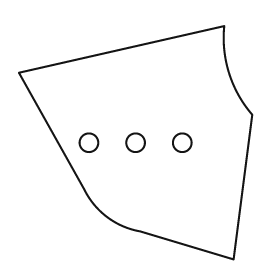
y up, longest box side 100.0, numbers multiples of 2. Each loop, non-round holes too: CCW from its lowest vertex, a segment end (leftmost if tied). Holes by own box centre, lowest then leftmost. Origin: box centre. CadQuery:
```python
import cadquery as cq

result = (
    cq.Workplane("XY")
    .moveTo(42.0, -50.0)
    .lineTo(50.0, 12.0)
    .threePointArc((40.0, 30.0), (38.0, 50.0))
    .lineTo(-50.0, 30.0)
    .lineTo(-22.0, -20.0)
    .threePointArc((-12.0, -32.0), (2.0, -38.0))
    .close()
    .moveTo(-20.0, 0.0)
    .circle(4.0)
    .moveTo(0.0, 0.0)
    .circle(4.0)
    .moveTo(20.0, 0.0)
    .circle(4.0)
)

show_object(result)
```